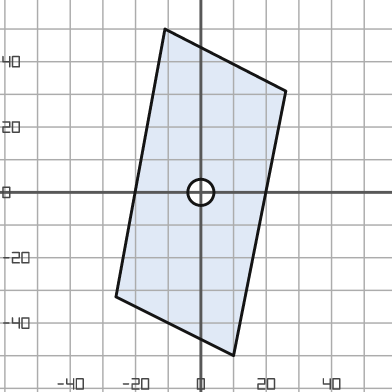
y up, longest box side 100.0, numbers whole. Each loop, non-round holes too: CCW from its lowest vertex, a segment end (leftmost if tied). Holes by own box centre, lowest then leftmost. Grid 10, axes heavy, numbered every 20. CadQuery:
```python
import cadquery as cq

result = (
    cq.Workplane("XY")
    .moveTo(10.0, -50.0)
    .lineTo(26.0, 31.0)
    .lineTo(-11.0, 50.0)
    .lineTo(-26.0, -32.0)
    .close()
    .moveTo(0.0, 0.0)
    .circle(4.0)
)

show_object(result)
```